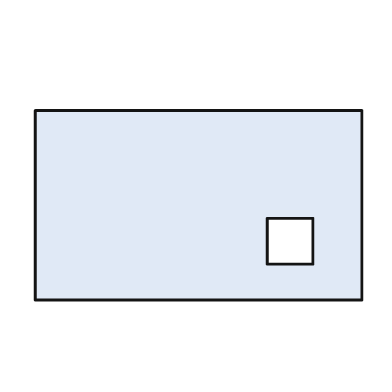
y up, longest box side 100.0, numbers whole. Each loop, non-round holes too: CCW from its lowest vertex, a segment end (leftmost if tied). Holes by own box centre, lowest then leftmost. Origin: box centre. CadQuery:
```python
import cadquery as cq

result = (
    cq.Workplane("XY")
    .moveTo(-50.0, -29.0)
    .lineTo(50.0, -29.0)
    .lineTo(50.0, 29.0)
    .lineTo(-50.0, 29.0)
    .close()
    .moveTo(21.0, -18.0)
    .lineTo(35.0, -18.0)
    .lineTo(35.0, -4.0)
    .lineTo(21.0, -4.0)
    .close()
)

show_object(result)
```